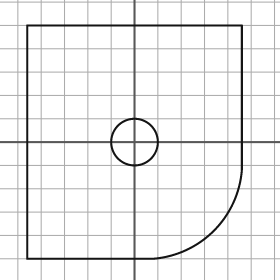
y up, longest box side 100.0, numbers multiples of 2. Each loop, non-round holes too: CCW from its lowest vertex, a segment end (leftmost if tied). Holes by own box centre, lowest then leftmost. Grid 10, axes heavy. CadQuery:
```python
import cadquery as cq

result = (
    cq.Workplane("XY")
    .moveTo(-46.0, -50.0)
    .lineTo(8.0, -50.0)
    .threePointArc((34.0, -38.0), (46.0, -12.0))
    .lineTo(46.0, 50.0)
    .lineTo(-46.0, 50.0)
    .close()
    .moveTo(0.0, 0.0)
    .circle(10.0)
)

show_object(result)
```